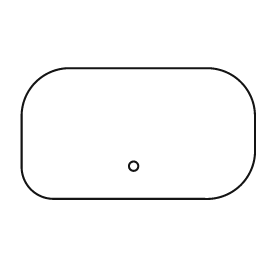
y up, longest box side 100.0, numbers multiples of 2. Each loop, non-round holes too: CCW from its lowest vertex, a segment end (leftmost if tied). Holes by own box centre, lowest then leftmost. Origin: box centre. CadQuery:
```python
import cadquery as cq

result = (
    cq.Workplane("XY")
    .moveTo(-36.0, -28.0)
    .lineTo(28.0, -28.0)
    .threePointArc((44.0, -22.0), (50.0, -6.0))
    .lineTo(50.0, 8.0)
    .threePointArc((44.0, 22.0), (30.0, 28.0))
    .lineTo(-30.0, 28.0)
    .threePointArc((-44.0, 22.0), (-50.0, 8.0))
    .lineTo(-50.0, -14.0)
    .threePointArc((-46.0, -24.0), (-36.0, -28.0))
    .close()
    .moveTo(-2.0, -14.0)
    .circle(2.0)
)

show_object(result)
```